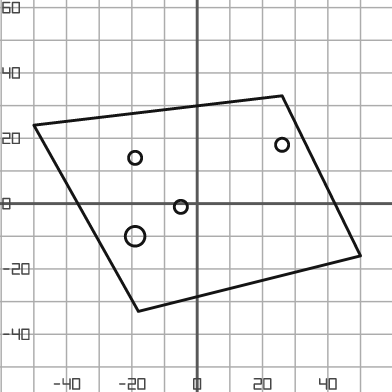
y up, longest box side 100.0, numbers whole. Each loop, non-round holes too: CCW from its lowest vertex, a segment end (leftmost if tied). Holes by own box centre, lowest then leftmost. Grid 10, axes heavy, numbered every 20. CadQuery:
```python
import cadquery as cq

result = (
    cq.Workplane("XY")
    .moveTo(-18.0, -33.0)
    .lineTo(50.0, -16.0)
    .lineTo(26.0, 33.0)
    .lineTo(-50.0, 24.0)
    .close()
    .moveTo(-19.0, -10.0)
    .circle(3.0)
    .moveTo(-5.0, -1.0)
    .circle(2.0)
    .moveTo(-19.0, 14.0)
    .circle(2.0)
    .moveTo(26.0, 18.0)
    .circle(2.0)
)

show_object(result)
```